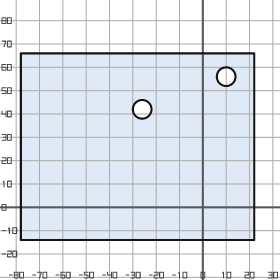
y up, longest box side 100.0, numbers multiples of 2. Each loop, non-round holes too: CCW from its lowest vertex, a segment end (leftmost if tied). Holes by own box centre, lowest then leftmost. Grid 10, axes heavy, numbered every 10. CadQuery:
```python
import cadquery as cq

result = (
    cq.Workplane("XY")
    .moveTo(-78.0, -14.0)
    .lineTo(22.0, -14.0)
    .lineTo(22.0, 66.0)
    .lineTo(-78.0, 66.0)
    .close()
    .moveTo(-26.0, 42.0)
    .circle(4.0)
    .moveTo(10.0, 56.0)
    .circle(4.0)
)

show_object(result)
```